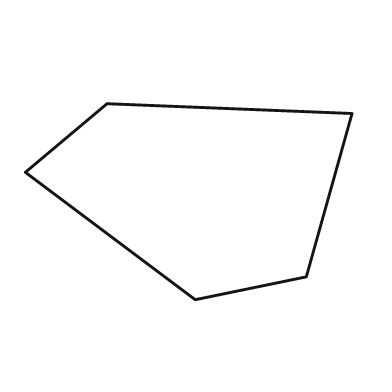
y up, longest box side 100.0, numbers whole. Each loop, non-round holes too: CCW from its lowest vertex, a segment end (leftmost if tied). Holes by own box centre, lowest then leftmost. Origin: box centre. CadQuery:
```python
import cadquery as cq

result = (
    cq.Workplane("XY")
    .moveTo(2.0, -30.0)
    .lineTo(36.0, -23.0)
    .lineTo(50.0, 27.0)
    .lineTo(-25.0, 30.0)
    .lineTo(-50.0, 9.0)
    .close()
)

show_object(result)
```